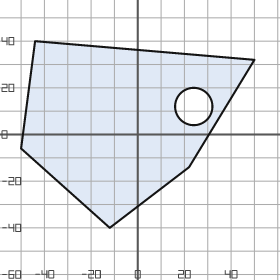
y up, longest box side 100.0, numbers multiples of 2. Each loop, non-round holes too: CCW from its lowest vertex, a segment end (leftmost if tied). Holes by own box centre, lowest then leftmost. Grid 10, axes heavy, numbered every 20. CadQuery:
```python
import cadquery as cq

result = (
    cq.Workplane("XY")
    .moveTo(-12.0, -40.0)
    .lineTo(22.0, -14.0)
    .lineTo(50.0, 32.0)
    .lineTo(-44.0, 40.0)
    .lineTo(-50.0, -6.0)
    .close()
    .moveTo(24.0, 12.0)
    .circle(8.0)
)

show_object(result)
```